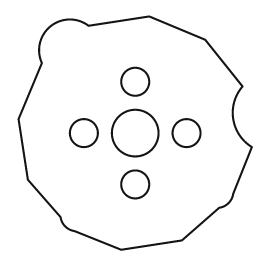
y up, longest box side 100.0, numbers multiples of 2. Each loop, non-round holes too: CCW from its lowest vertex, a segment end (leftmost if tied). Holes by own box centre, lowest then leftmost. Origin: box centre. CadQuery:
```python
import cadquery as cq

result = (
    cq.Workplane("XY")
    .moveTo(-6.0, -50.0)
    .lineTo(20.0, -46.0)
    .lineTo(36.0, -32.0)
    .threePointArc((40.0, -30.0), (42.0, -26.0))
    .lineTo(50.0, -6.0)
    .threePointArc((42.0, 6.0), (46.0, 20.0))
    .lineTo(30.0, 40.0)
    .lineTo(6.0, 50.0)
    .lineTo(-20.0, 46.0)
    .threePointArc((-36.0, 46.0), (-40.0, 30.0))
    .lineTo(-50.0, 6.0)
    .lineTo(-46.0, -20.0)
    .lineTo(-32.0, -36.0)
    .threePointArc((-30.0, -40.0), (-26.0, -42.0))
    .close()
    .moveTo(0.0, -22.0)
    .circle(6.0)
    .moveTo(-22.0, 0.0)
    .circle(6.0)
    .moveTo(0.0, 0.0)
    .circle(10.0)
    .moveTo(22.0, 0.0)
    .circle(6.0)
    .moveTo(0.0, 22.0)
    .circle(6.0)
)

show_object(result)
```